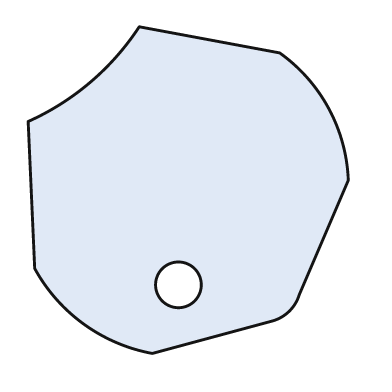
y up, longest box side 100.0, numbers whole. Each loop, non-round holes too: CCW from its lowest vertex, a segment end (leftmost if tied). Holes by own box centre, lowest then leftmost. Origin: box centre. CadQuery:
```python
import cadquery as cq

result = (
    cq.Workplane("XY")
    .moveTo(-11.0, -50.0)
    .lineTo(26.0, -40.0)
    .threePointArc((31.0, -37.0), (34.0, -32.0))
    .lineTo(49.0, 3.0)
    .threePointArc((43.0, 25.0), (28.0, 42.0))
    .lineTo(-15.0, 50.0)
    .threePointArc((-30.0, 33.0), (-49.0, 21.0))
    .lineTo(-47.0, -24.0)
    .threePointArc((-32.0, -41.0), (-11.0, -50.0))
    .close()
    .moveTo(-3.0, -29.0)
    .circle(7.0)
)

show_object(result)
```